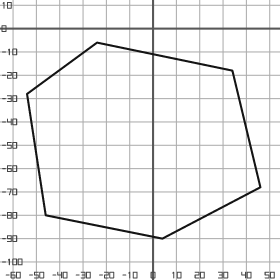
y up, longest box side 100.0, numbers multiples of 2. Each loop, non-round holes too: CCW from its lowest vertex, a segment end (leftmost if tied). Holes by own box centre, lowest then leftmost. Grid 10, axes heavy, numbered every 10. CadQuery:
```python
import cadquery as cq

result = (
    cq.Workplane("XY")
    .moveTo(4.0, -90.0)
    .lineTo(46.0, -68.0)
    .lineTo(34.0, -18.0)
    .lineTo(-24.0, -6.0)
    .lineTo(-54.0, -28.0)
    .lineTo(-46.0, -80.0)
    .close()
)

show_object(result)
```